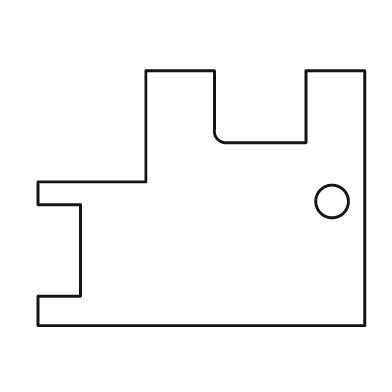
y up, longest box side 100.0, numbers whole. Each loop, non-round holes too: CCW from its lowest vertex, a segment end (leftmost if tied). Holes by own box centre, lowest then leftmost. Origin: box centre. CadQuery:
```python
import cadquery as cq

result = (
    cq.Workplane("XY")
    .moveTo(-50.0, -39.0)
    .lineTo(50.0, -39.0)
    .lineTo(50.0, 39.0)
    .lineTo(32.0, 39.0)
    .lineTo(32.0, 17.0)
    .lineTo(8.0, 17.0)
    .threePointArc((5.0, 18.0), (4.0, 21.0))
    .lineTo(4.0, 39.0)
    .lineTo(-17.0, 39.0)
    .lineTo(-17.0, 5.0)
    .lineTo(-50.0, 5.0)
    .lineTo(-50.0, -2.0)
    .lineTo(-37.0, -2.0)
    .lineTo(-37.0, -30.0)
    .lineTo(-50.0, -30.0)
    .close()
    .moveTo(40.0, -1.0)
    .circle(5.0)
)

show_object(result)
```